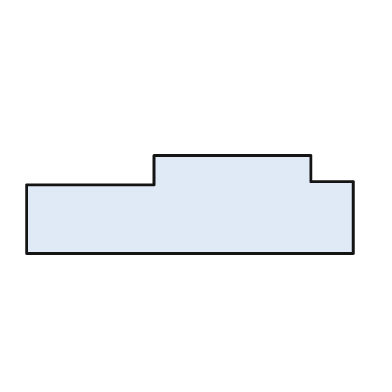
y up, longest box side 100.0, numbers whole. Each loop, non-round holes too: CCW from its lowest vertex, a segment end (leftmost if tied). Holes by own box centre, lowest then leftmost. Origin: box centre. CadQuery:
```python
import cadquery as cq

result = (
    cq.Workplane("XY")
    .moveTo(-50.0, -15.0)
    .lineTo(50.0, -15.0)
    .lineTo(50.0, 7.0)
    .lineTo(37.0, 7.0)
    .lineTo(37.0, 15.0)
    .lineTo(-11.0, 15.0)
    .lineTo(-11.0, 6.0)
    .lineTo(-50.0, 6.0)
    .close()
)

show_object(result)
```